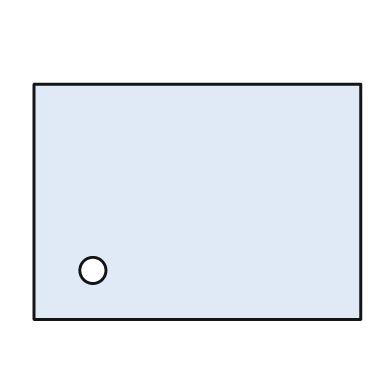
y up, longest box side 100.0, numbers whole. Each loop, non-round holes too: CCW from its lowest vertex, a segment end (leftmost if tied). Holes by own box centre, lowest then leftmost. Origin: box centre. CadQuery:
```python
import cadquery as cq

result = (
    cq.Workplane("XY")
    .moveTo(-50.0, -36.0)
    .lineTo(50.0, -36.0)
    .lineTo(50.0, 36.0)
    .lineTo(-50.0, 36.0)
    .close()
    .moveTo(-32.0, -21.0)
    .circle(4.0)
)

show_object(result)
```